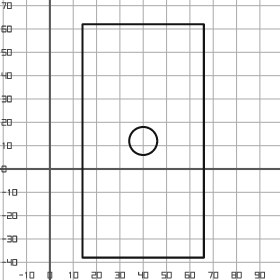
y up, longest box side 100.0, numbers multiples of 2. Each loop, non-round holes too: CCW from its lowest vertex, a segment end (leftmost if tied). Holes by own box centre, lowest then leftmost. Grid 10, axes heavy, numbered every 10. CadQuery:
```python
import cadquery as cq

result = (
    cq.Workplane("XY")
    .moveTo(14.0, -38.0)
    .lineTo(66.0, -38.0)
    .lineTo(66.0, 62.0)
    .lineTo(14.0, 62.0)
    .close()
    .moveTo(40.0, 12.0)
    .circle(6.0)
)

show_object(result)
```